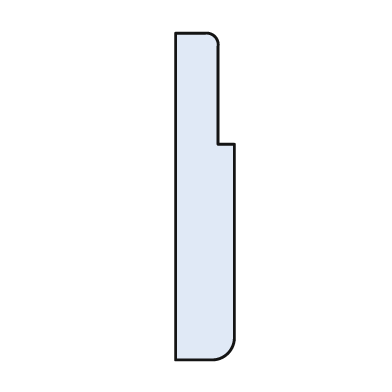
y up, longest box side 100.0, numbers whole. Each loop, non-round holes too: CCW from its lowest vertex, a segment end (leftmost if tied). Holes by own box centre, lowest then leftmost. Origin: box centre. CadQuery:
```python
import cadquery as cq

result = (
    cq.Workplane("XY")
    .moveTo(-9.0, -50.0)
    .lineTo(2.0, -50.0)
    .threePointArc((7.0, -48.0), (9.0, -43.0))
    .lineTo(9.0, 16.0)
    .lineTo(4.0, 16.0)
    .lineTo(4.0, 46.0)
    .threePointArc((3.0, 49.0), (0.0, 50.0))
    .lineTo(-9.0, 50.0)
    .close()
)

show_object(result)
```